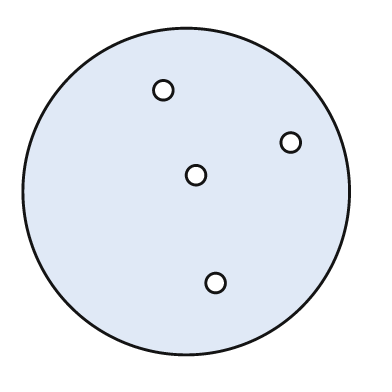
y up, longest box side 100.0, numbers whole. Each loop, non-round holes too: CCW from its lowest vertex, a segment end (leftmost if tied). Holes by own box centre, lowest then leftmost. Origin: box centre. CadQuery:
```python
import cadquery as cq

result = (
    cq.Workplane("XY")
    .moveTo(0.0, 0.0)
    .circle(50.0)
    .moveTo(9.0, -28.0)
    .circle(3.0)
    .moveTo(3.0, 5.0)
    .circle(3.0)
    .moveTo(32.0, 15.0)
    .circle(3.0)
    .moveTo(-7.0, 31.0)
    .circle(3.0)
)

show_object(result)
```